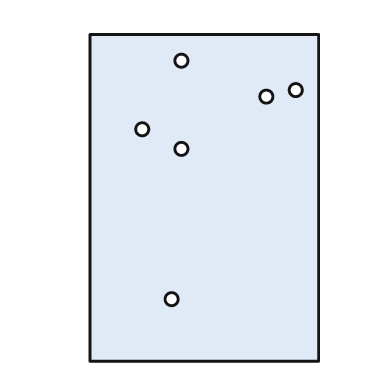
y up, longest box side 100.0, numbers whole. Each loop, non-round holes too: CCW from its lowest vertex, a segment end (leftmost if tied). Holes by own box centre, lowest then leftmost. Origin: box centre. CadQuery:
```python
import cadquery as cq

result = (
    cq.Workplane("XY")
    .moveTo(-35.0, -50.0)
    .lineTo(35.0, -50.0)
    .lineTo(35.0, 50.0)
    .lineTo(-35.0, 50.0)
    .close()
    .moveTo(-10.0, -31.0)
    .circle(2.0)
    .moveTo(-7.0, 15.0)
    .circle(2.0)
    .moveTo(-19.0, 21.0)
    .circle(2.0)
    .moveTo(19.0, 31.0)
    .circle(2.0)
    .moveTo(28.0, 33.0)
    .circle(2.0)
    .moveTo(-7.0, 42.0)
    .circle(2.0)
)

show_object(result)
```